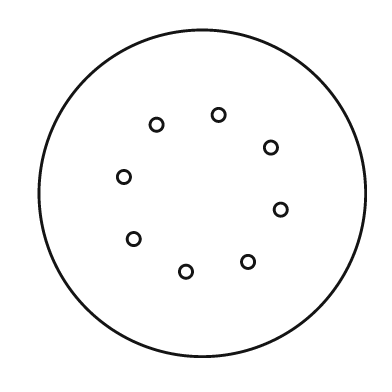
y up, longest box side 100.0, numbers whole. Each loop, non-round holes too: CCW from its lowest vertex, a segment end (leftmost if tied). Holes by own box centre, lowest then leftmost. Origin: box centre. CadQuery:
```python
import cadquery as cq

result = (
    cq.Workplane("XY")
    .moveTo(0.0, 0.0)
    .circle(50.0)
    .moveTo(-5.0, -24.0)
    .circle(2.0)
    .moveTo(14.0, -21.0)
    .circle(2.0)
    .moveTo(-21.0, -14.0)
    .circle(2.0)
    .moveTo(24.0, -5.0)
    .circle(2.0)
    .moveTo(-24.0, 5.0)
    .circle(2.0)
    .moveTo(21.0, 14.0)
    .circle(2.0)
    .moveTo(-14.0, 21.0)
    .circle(2.0)
    .moveTo(5.0, 24.0)
    .circle(2.0)
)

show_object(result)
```